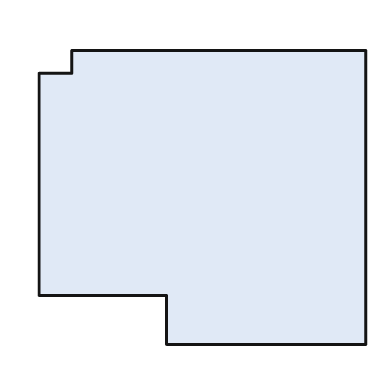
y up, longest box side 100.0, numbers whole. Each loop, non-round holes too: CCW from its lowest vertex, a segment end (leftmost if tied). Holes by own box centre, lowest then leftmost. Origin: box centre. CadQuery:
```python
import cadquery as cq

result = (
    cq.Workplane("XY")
    .moveTo(-11.0, -45.0)
    .lineTo(50.0, -45.0)
    .lineTo(50.0, 45.0)
    .lineTo(-40.0, 45.0)
    .lineTo(-40.0, 38.0)
    .lineTo(-50.0, 38.0)
    .lineTo(-50.0, -30.0)
    .lineTo(-11.0, -30.0)
    .close()
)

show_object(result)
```